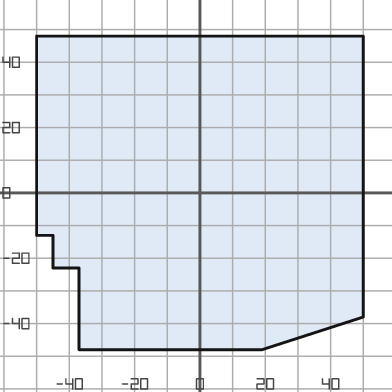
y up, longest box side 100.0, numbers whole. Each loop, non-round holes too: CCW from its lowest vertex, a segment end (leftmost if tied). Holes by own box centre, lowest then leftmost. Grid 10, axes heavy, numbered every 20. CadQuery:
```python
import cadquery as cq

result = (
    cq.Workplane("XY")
    .moveTo(-37.0, -48.0)
    .lineTo(19.0, -48.0)
    .lineTo(50.0, -38.0)
    .lineTo(50.0, 48.0)
    .lineTo(-50.0, 48.0)
    .lineTo(-50.0, -13.0)
    .lineTo(-45.0, -13.0)
    .lineTo(-45.0, -23.0)
    .lineTo(-37.0, -23.0)
    .close()
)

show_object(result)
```